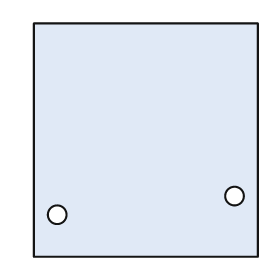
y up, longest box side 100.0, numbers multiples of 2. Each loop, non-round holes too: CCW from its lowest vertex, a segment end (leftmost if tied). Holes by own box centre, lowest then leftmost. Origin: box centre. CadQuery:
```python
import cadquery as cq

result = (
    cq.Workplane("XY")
    .moveTo(-48.0, -50.0)
    .lineTo(48.0, -50.0)
    .lineTo(48.0, 50.0)
    .lineTo(-48.0, 50.0)
    .close()
    .moveTo(-38.0, -32.0)
    .circle(4.0)
    .moveTo(38.0, -24.0)
    .circle(4.0)
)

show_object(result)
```